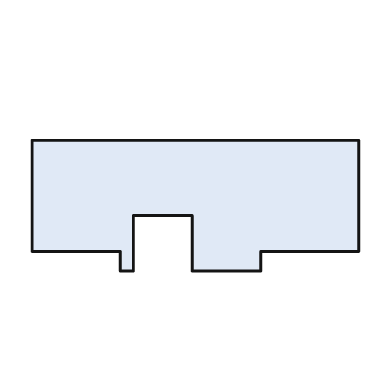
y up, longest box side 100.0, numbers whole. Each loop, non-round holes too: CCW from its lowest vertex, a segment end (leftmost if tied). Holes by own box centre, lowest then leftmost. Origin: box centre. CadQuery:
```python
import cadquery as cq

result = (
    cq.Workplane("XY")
    .moveTo(-23.0, -20.0)
    .lineTo(-19.0, -20.0)
    .lineTo(-19.0, -3.0)
    .lineTo(-1.0, -3.0)
    .lineTo(-1.0, -20.0)
    .lineTo(20.0, -20.0)
    .lineTo(20.0, -14.0)
    .lineTo(50.0, -14.0)
    .lineTo(50.0, 20.0)
    .lineTo(-50.0, 20.0)
    .lineTo(-50.0, -14.0)
    .lineTo(-23.0, -14.0)
    .close()
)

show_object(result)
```